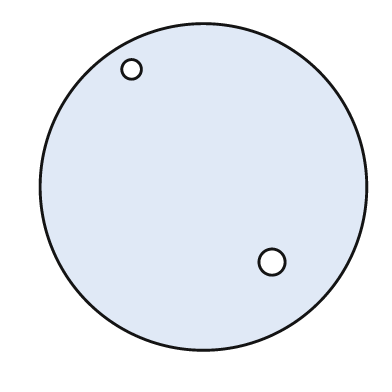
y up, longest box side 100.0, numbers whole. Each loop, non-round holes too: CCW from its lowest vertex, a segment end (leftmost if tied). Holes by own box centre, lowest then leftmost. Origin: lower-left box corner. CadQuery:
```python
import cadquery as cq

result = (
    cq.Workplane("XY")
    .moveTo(50.0, 50.0)
    .circle(50.0)
    .moveTo(71.0, 27.0)
    .circle(4.0)
    .moveTo(28.0, 86.0)
    .circle(3.0)
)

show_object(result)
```